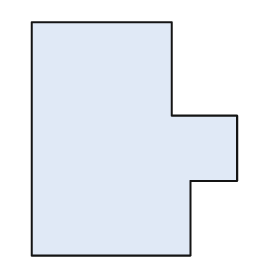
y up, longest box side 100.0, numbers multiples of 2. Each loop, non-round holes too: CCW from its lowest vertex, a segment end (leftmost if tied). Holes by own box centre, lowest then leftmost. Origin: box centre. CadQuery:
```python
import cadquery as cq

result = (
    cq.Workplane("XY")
    .moveTo(-44.0, -50.0)
    .lineTo(24.0, -50.0)
    .lineTo(24.0, -18.0)
    .lineTo(44.0, -18.0)
    .lineTo(44.0, 10.0)
    .lineTo(16.0, 10.0)
    .lineTo(16.0, 50.0)
    .lineTo(-44.0, 50.0)
    .close()
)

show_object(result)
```